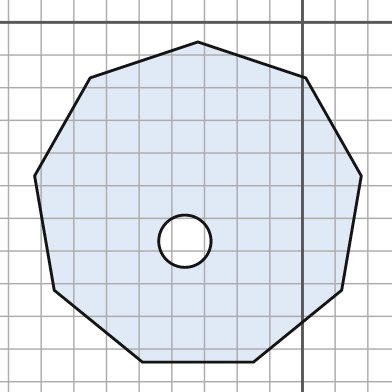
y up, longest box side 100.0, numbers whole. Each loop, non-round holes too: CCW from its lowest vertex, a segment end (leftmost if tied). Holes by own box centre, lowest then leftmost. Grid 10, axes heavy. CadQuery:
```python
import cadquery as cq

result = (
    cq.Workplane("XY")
    .moveTo(-49.0, -104.0)
    .lineTo(-15.0, -104.0)
    .lineTo(12.0, -82.0)
    .lineTo(18.0, -47.0)
    .lineTo(1.0, -17.0)
    .lineTo(-32.0, -6.0)
    .lineTo(-65.0, -17.0)
    .lineTo(-82.0, -47.0)
    .lineTo(-76.0, -82.0)
    .close()
    .moveTo(-36.0, -67.0)
    .circle(8.0)
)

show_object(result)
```